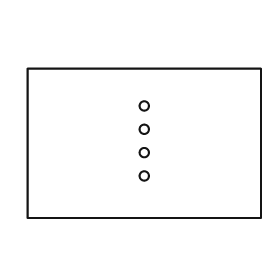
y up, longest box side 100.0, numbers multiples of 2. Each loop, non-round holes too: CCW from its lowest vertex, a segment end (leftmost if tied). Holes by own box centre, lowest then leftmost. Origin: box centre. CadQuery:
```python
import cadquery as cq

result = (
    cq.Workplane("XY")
    .moveTo(-50.0, -32.0)
    .lineTo(50.0, -32.0)
    .lineTo(50.0, 32.0)
    .lineTo(-50.0, 32.0)
    .close()
    .moveTo(0.0, -14.0)
    .circle(2.0)
    .moveTo(0.0, -4.0)
    .circle(2.0)
    .moveTo(0.0, 6.0)
    .circle(2.0)
    .moveTo(0.0, 16.0)
    .circle(2.0)
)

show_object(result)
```